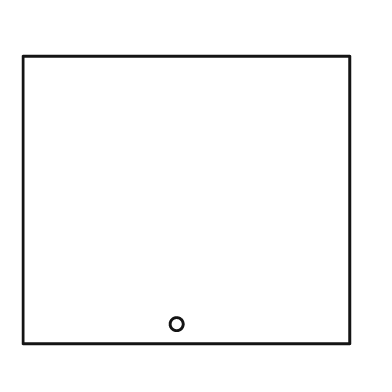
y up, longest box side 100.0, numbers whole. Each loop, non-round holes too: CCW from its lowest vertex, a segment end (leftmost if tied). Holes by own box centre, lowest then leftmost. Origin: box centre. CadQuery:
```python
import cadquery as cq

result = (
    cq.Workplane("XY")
    .moveTo(-50.0, -44.0)
    .lineTo(50.0, -44.0)
    .lineTo(50.0, 44.0)
    .lineTo(-50.0, 44.0)
    .close()
    .moveTo(-3.0, -38.0)
    .circle(2.0)
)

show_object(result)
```